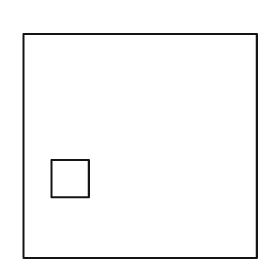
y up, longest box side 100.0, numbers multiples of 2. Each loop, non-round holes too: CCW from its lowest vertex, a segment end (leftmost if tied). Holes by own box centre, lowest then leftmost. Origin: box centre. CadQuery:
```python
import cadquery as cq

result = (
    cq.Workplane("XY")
    .moveTo(-50.0, -48.0)
    .lineTo(50.0, -48.0)
    .lineTo(50.0, 48.0)
    .lineTo(-50.0, 48.0)
    .close()
    .moveTo(-38.0, -22.0)
    .lineTo(-22.0, -22.0)
    .lineTo(-22.0, -6.0)
    .lineTo(-38.0, -6.0)
    .close()
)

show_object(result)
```